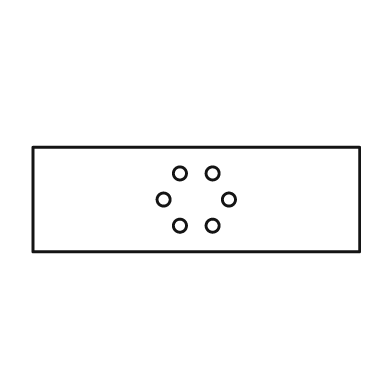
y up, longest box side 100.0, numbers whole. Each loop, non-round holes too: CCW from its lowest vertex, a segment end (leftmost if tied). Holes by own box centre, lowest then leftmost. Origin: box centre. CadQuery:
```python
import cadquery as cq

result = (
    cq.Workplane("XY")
    .moveTo(-50.0, -16.0)
    .lineTo(50.0, -16.0)
    .lineTo(50.0, 16.0)
    .lineTo(-50.0, 16.0)
    .close()
    .moveTo(-5.0, -8.0)
    .circle(2.0)
    .moveTo(5.0, -8.0)
    .circle(2.0)
    .moveTo(-10.0, 0.0)
    .circle(2.0)
    .moveTo(10.0, 0.0)
    .circle(2.0)
    .moveTo(-5.0, 8.0)
    .circle(2.0)
    .moveTo(5.0, 8.0)
    .circle(2.0)
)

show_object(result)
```